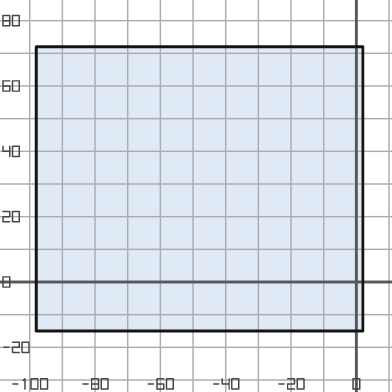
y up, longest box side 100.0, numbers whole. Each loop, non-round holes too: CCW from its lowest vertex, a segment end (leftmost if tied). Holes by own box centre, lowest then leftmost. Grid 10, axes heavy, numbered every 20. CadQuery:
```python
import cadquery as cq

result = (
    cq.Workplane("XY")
    .moveTo(-98.0, -15.0)
    .lineTo(2.0, -15.0)
    .lineTo(2.0, 72.0)
    .lineTo(-98.0, 72.0)
    .close()
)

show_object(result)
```